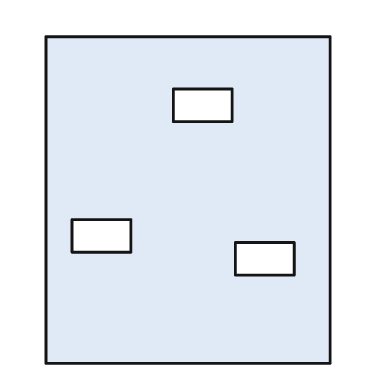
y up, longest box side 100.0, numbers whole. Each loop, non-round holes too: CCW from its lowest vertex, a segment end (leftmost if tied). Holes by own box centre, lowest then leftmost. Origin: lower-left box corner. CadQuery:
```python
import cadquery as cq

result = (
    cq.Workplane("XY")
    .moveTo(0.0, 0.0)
    .lineTo(87.0, 0.0)
    .lineTo(87.0, 100.0)
    .lineTo(0.0, 100.0)
    .close()
    .moveTo(58.0, 27.0)
    .lineTo(76.0, 27.0)
    .lineTo(76.0, 37.0)
    .lineTo(58.0, 37.0)
    .close()
    .moveTo(8.0, 34.0)
    .lineTo(26.0, 34.0)
    .lineTo(26.0, 44.0)
    .lineTo(8.0, 44.0)
    .close()
    .moveTo(39.0, 74.0)
    .lineTo(57.0, 74.0)
    .lineTo(57.0, 84.0)
    .lineTo(39.0, 84.0)
    .close()
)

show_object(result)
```